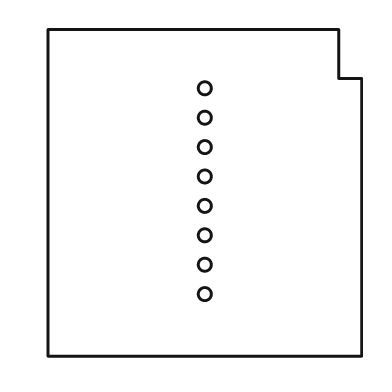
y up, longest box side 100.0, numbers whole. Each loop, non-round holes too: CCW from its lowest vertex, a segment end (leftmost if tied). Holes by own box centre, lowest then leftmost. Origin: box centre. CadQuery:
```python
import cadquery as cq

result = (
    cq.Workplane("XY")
    .moveTo(-48.0, -50.0)
    .lineTo(48.0, -50.0)
    .lineTo(48.0, 35.0)
    .lineTo(41.0, 35.0)
    .lineTo(41.0, 50.0)
    .lineTo(-48.0, 50.0)
    .close()
    .moveTo(0.0, -31.0)
    .circle(2.0)
    .moveTo(0.0, -22.0)
    .circle(2.0)
    .moveTo(0.0, -13.0)
    .circle(2.0)
    .moveTo(0.0, -4.0)
    .circle(2.0)
    .moveTo(0.0, 5.0)
    .circle(2.0)
    .moveTo(0.0, 14.0)
    .circle(2.0)
    .moveTo(0.0, 23.0)
    .circle(2.0)
    .moveTo(0.0, 32.0)
    .circle(2.0)
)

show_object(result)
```